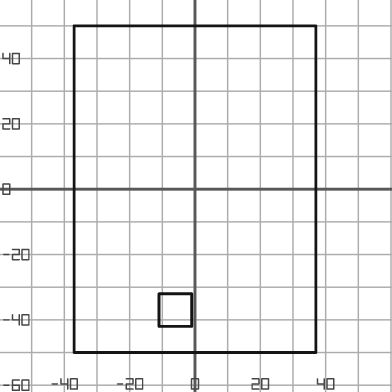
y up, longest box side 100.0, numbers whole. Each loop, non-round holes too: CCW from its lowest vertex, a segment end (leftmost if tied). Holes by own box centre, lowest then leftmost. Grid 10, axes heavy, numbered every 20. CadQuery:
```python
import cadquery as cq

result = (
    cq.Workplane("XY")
    .moveTo(-37.0, -50.0)
    .lineTo(37.0, -50.0)
    .lineTo(37.0, 50.0)
    .lineTo(-37.0, 50.0)
    .close()
    .moveTo(-11.0, -42.0)
    .lineTo(-1.0, -42.0)
    .lineTo(-1.0, -32.0)
    .lineTo(-11.0, -32.0)
    .close()
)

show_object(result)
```